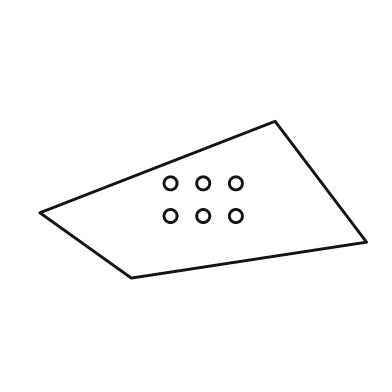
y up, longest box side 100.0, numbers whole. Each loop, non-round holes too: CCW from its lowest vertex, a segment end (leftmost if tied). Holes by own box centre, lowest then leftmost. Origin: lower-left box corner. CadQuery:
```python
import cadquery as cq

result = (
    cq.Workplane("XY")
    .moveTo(28.0, 0.0)
    .lineTo(100.0, 11.0)
    .lineTo(72.0, 48.0)
    .lineTo(0.0, 20.0)
    .close()
    .moveTo(40.0, 19.0)
    .circle(2.0)
    .moveTo(50.0, 19.0)
    .circle(2.0)
    .moveTo(60.0, 19.0)
    .circle(2.0)
    .moveTo(40.0, 29.0)
    .circle(2.0)
    .moveTo(50.0, 29.0)
    .circle(2.0)
    .moveTo(60.0, 29.0)
    .circle(2.0)
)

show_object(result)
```